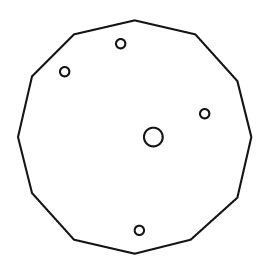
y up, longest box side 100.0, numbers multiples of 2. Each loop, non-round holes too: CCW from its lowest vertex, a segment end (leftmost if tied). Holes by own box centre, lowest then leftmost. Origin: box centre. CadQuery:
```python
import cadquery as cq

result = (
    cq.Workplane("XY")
    .moveTo(0.0, -50.0)
    .lineTo(24.0, -44.0)
    .lineTo(44.0, -26.0)
    .lineTo(50.0, 0.0)
    .lineTo(44.0, 24.0)
    .lineTo(26.0, 44.0)
    .lineTo(0.0, 50.0)
    .lineTo(-26.0, 44.0)
    .lineTo(-44.0, 26.0)
    .lineTo(-50.0, 0.0)
    .lineTo(-44.0, -24.0)
    .lineTo(-26.0, -44.0)
    .close()
    .moveTo(2.0, -40.0)
    .circle(2.0)
    .moveTo(8.0, 0.0)
    .circle(4.0)
    .moveTo(30.0, 10.0)
    .circle(2.0)
    .moveTo(-30.0, 28.0)
    .circle(2.0)
    .moveTo(-6.0, 40.0)
    .circle(2.0)
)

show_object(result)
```